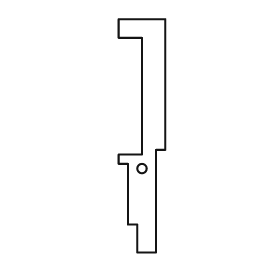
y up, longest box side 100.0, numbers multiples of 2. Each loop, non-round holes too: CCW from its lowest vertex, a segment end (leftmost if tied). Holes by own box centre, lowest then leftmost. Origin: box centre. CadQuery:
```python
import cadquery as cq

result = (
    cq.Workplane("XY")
    .moveTo(-2.0, -50.0)
    .lineTo(6.0, -50.0)
    .lineTo(6.0, -6.0)
    .lineTo(10.0, -6.0)
    .lineTo(10.0, 50.0)
    .lineTo(-10.0, 50.0)
    .lineTo(-10.0, 42.0)
    .lineTo(0.0, 42.0)
    .lineTo(0.0, -8.0)
    .lineTo(-10.0, -8.0)
    .lineTo(-10.0, -12.0)
    .lineTo(-6.0, -12.0)
    .lineTo(-6.0, -38.0)
    .lineTo(-2.0, -38.0)
    .close()
    .moveTo(0.0, -14.0)
    .circle(2.0)
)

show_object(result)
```